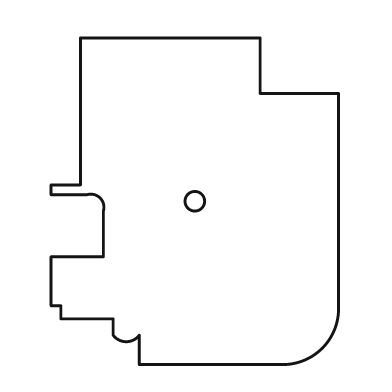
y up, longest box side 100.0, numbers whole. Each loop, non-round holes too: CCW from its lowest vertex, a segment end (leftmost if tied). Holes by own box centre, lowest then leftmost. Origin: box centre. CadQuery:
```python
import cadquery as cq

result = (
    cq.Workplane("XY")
    .moveTo(-17.0, -50.0)
    .lineTo(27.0, -50.0)
    .threePointArc((39.0, -45.0), (44.0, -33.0))
    .lineTo(44.0, 33.0)
    .lineTo(20.0, 33.0)
    .lineTo(20.0, 50.0)
    .lineTo(-35.0, 50.0)
    .lineTo(-35.0, 5.0)
    .lineTo(-44.0, 5.0)
    .lineTo(-44.0, 2.0)
    .lineTo(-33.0, 2.0)
    .threePointArc((-29.0, 1.0), (-28.0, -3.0))
    .lineTo(-28.0, -17.0)
    .lineTo(-44.0, -17.0)
    .lineTo(-44.0, -32.0)
    .lineTo(-41.0, -32.0)
    .lineTo(-41.0, -36.0)
    .lineTo(-25.0, -36.0)
    .lineTo(-25.0, -41.0)
    .threePointArc((-21.0, -43.0), (-17.0, -41.0))
    .close()
    .moveTo(0.0, 0.0)
    .circle(3.0)
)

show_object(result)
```